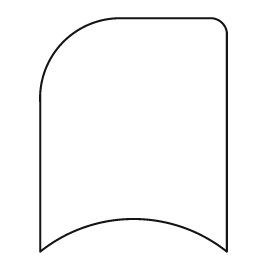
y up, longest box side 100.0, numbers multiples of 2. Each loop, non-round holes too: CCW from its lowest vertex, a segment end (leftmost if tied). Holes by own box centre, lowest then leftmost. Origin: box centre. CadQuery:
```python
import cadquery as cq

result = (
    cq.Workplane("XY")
    .moveTo(-40.0, -50.0)
    .threePointArc((0.0, -36.0), (40.0, -50.0))
    .lineTo(40.0, 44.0)
    .threePointArc((38.0, 48.0), (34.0, 50.0))
    .lineTo(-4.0, 50.0)
    .threePointArc((-30.0, 40.0), (-40.0, 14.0))
    .close()
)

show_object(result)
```